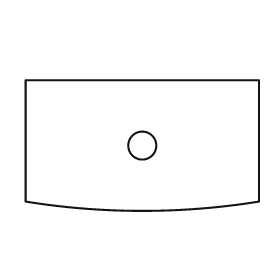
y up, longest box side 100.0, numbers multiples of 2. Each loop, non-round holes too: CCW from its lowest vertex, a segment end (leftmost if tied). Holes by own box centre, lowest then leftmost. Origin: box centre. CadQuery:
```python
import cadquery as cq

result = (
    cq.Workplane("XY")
    .moveTo(-50.0, -24.0)
    .threePointArc((0.0, -28.0), (50.0, -24.0))
    .lineTo(50.0, 28.0)
    .lineTo(-50.0, 28.0)
    .close()
    .moveTo(0.0, 0.0)
    .circle(6.0)
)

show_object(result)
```